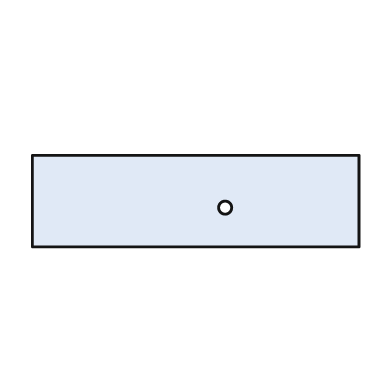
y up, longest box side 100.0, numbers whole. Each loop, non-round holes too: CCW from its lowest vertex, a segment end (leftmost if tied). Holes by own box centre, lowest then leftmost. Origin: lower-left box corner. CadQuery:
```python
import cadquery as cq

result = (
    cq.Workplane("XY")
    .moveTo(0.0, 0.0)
    .lineTo(100.0, 0.0)
    .lineTo(100.0, 28.0)
    .lineTo(0.0, 28.0)
    .close()
    .moveTo(59.0, 12.0)
    .circle(2.0)
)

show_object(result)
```